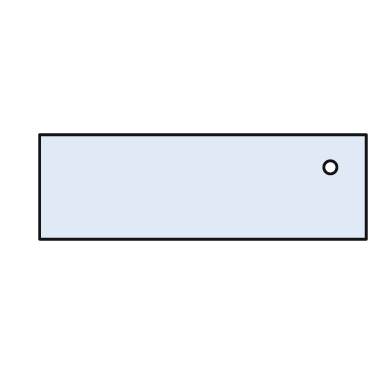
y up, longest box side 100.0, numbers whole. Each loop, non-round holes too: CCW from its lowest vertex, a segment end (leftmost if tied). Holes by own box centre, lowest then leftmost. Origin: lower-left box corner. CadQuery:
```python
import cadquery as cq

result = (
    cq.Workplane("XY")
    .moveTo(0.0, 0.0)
    .lineTo(100.0, 0.0)
    .lineTo(100.0, 32.0)
    .lineTo(0.0, 32.0)
    .close()
    .moveTo(89.0, 22.0)
    .circle(2.0)
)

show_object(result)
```